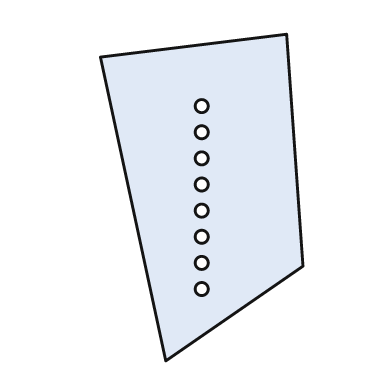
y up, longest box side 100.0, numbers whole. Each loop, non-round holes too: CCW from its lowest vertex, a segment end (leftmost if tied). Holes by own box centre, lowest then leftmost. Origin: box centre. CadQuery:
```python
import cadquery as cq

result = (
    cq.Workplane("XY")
    .moveTo(-11.0, -50.0)
    .lineTo(31.0, -21.0)
    .lineTo(26.0, 50.0)
    .lineTo(-31.0, 43.0)
    .close()
    .moveTo(0.0, -28.0)
    .circle(2.0)
    .moveTo(0.0, -20.0)
    .circle(2.0)
    .moveTo(0.0, -12.0)
    .circle(2.0)
    .moveTo(0.0, -4.0)
    .circle(2.0)
    .moveTo(0.0, 4.0)
    .circle(2.0)
    .moveTo(0.0, 12.0)
    .circle(2.0)
    .moveTo(0.0, 20.0)
    .circle(2.0)
    .moveTo(0.0, 28.0)
    .circle(2.0)
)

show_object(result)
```